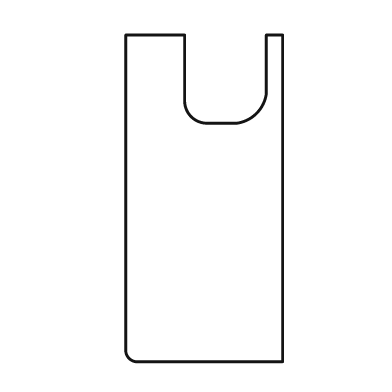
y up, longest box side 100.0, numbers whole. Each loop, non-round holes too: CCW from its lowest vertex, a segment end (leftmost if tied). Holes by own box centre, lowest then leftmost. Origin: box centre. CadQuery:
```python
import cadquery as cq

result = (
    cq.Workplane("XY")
    .moveTo(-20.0, -50.0)
    .lineTo(24.0, -50.0)
    .lineTo(24.0, 50.0)
    .lineTo(19.0, 50.0)
    .lineTo(19.0, 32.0)
    .threePointArc((16.0, 26.0), (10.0, 23.0))
    .lineTo(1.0, 23.0)
    .threePointArc((-4.0, 25.0), (-6.0, 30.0))
    .lineTo(-6.0, 50.0)
    .lineTo(-24.0, 50.0)
    .lineTo(-24.0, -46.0)
    .threePointArc((-23.0, -49.0), (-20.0, -50.0))
    .close()
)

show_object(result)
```